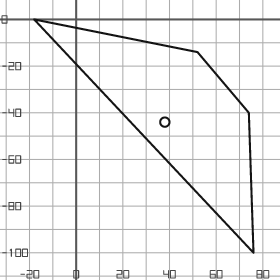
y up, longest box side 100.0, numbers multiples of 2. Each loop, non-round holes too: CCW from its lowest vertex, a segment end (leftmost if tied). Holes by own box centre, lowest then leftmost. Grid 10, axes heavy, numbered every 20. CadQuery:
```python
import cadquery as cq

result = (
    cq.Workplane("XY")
    .moveTo(76.0, -100.0)
    .lineTo(74.0, -40.0)
    .lineTo(52.0, -14.0)
    .lineTo(-18.0, 0.0)
    .close()
    .moveTo(38.0, -44.0)
    .circle(2.0)
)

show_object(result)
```